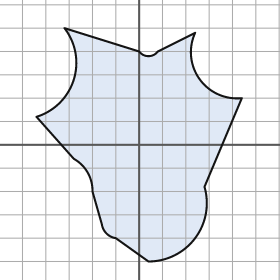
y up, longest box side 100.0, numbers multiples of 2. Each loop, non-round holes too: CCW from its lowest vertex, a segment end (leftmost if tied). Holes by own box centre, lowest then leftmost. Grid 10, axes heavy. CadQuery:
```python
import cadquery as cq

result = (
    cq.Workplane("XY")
    .moveTo(4.0, -50.0)
    .threePointArc((24.0, -40.0), (28.0, -18.0))
    .lineTo(44.0, 20.0)
    .threePointArc((26.0, 28.0), (24.0, 48.0))
    .lineTo(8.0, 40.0)
    .threePointArc((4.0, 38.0), (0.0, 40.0))
    .lineTo(-32.0, 50.0)
    .threePointArc((-28.0, 28.0), (-44.0, 12.0))
    .lineTo(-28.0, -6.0)
    .threePointArc((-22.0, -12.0), (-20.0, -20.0))
    .lineTo(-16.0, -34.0)
    .threePointArc((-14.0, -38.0), (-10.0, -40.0))
    .close()
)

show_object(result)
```